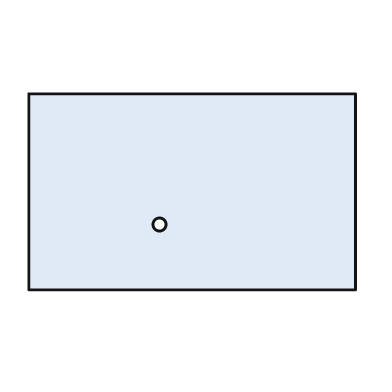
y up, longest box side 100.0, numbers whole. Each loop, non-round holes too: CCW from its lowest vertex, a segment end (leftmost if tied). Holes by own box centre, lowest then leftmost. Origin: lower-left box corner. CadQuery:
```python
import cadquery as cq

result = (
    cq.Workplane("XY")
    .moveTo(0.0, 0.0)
    .lineTo(100.0, 0.0)
    .lineTo(100.0, 60.0)
    .lineTo(0.0, 60.0)
    .close()
    .moveTo(40.0, 20.0)
    .circle(2.0)
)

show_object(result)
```